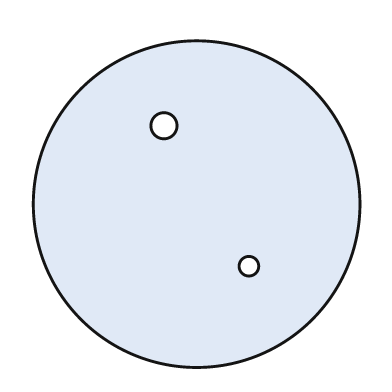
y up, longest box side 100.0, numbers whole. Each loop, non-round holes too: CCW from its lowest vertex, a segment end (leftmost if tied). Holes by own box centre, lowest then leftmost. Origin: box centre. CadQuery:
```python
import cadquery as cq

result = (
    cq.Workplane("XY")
    .moveTo(0.0, 0.0)
    .circle(50.0)
    .moveTo(16.0, -19.0)
    .circle(3.0)
    .moveTo(-10.0, 24.0)
    .circle(4.0)
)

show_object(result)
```